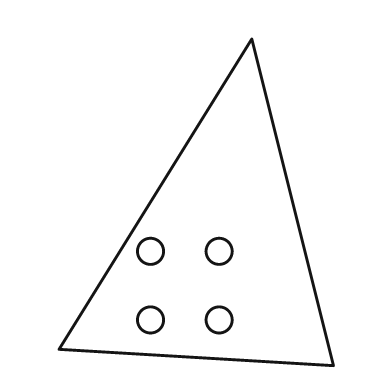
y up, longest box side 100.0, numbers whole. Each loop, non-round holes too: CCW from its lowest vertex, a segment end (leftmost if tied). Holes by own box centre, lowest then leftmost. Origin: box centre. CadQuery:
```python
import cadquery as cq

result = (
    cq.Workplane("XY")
    .moveTo(42.0, -50.0)
    .lineTo(17.0, 50.0)
    .lineTo(-42.0, -45.0)
    .close()
    .moveTo(-14.0, -36.0)
    .circle(4.0)
    .moveTo(7.0, -36.0)
    .circle(4.0)
    .moveTo(-14.0, -15.0)
    .circle(4.0)
    .moveTo(7.0, -15.0)
    .circle(4.0)
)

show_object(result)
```